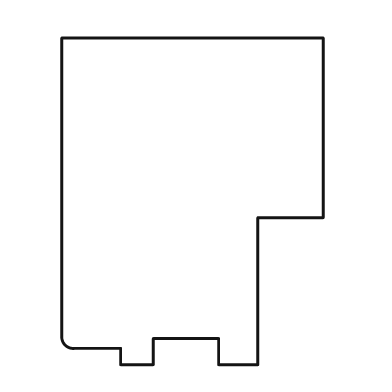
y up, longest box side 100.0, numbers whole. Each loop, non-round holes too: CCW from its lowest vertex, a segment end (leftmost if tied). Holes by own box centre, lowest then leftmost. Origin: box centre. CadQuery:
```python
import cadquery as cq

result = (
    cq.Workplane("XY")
    .moveTo(-22.0, -50.0)
    .lineTo(-12.0, -50.0)
    .lineTo(-12.0, -42.0)
    .lineTo(8.0, -42.0)
    .lineTo(8.0, -50.0)
    .lineTo(20.0, -50.0)
    .lineTo(20.0, -5.0)
    .lineTo(40.0, -5.0)
    .lineTo(40.0, 50.0)
    .lineTo(-40.0, 50.0)
    .lineTo(-40.0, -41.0)
    .threePointArc((-39.0, -44.0), (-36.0, -45.0))
    .lineTo(-22.0, -45.0)
    .close()
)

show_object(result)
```